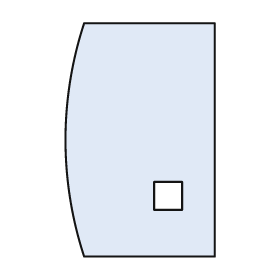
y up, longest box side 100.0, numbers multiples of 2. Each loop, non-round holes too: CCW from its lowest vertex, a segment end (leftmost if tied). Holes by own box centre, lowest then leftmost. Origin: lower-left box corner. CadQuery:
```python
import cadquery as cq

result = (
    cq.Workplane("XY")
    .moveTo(8.0, 0.0)
    .lineTo(64.0, 0.0)
    .lineTo(64.0, 100.0)
    .lineTo(8.0, 100.0)
    .threePointArc((0.0, 50.0), (8.0, 0.0))
    .close()
    .moveTo(38.0, 20.0)
    .lineTo(50.0, 20.0)
    .lineTo(50.0, 32.0)
    .lineTo(38.0, 32.0)
    .close()
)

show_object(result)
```